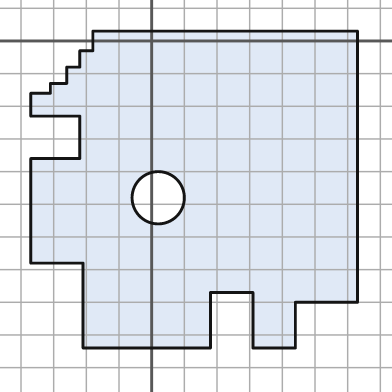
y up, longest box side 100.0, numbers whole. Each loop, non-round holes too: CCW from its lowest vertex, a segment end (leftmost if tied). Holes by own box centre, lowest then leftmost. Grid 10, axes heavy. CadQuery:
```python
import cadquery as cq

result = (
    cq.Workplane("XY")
    .moveTo(-21.0, -94.0)
    .lineTo(18.0, -94.0)
    .lineTo(18.0, -77.0)
    .lineTo(31.0, -77.0)
    .lineTo(31.0, -94.0)
    .lineTo(44.0, -94.0)
    .lineTo(44.0, -80.0)
    .lineTo(63.0, -80.0)
    .lineTo(63.0, 3.0)
    .lineTo(-18.0, 3.0)
    .lineTo(-18.0, -3.0)
    .lineTo(-22.0, -3.0)
    .lineTo(-22.0, -8.0)
    .lineTo(-26.0, -8.0)
    .lineTo(-26.0, -13.0)
    .lineTo(-31.0, -13.0)
    .lineTo(-31.0, -16.0)
    .lineTo(-37.0, -16.0)
    .lineTo(-37.0, -23.0)
    .lineTo(-22.0, -23.0)
    .lineTo(-22.0, -36.0)
    .lineTo(-37.0, -36.0)
    .lineTo(-37.0, -68.0)
    .lineTo(-21.0, -68.0)
    .close()
    .moveTo(2.0, -48.0)
    .circle(8.0)
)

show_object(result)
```